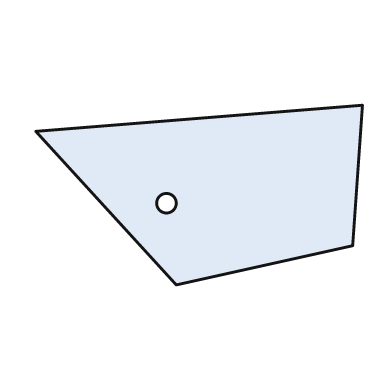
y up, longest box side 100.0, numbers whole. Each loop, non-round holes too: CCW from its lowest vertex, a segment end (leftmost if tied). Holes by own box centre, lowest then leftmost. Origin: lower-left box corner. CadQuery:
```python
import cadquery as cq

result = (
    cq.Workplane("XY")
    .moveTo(43.0, 0.0)
    .lineTo(97.0, 12.0)
    .lineTo(100.0, 55.0)
    .lineTo(0.0, 47.0)
    .close()
    .moveTo(40.0, 25.0)
    .circle(3.0)
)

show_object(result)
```